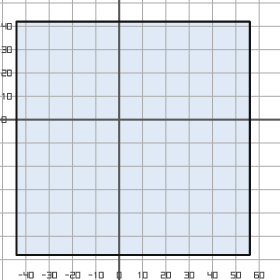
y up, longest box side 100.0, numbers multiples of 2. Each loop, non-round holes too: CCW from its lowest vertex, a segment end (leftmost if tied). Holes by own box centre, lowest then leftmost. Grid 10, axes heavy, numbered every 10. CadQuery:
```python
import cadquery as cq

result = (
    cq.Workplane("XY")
    .moveTo(-44.0, -58.0)
    .lineTo(56.0, -58.0)
    .lineTo(56.0, 42.0)
    .lineTo(-44.0, 42.0)
    .close()
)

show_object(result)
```